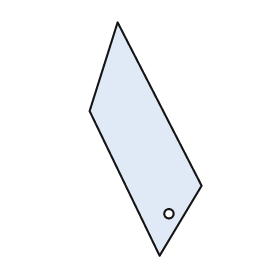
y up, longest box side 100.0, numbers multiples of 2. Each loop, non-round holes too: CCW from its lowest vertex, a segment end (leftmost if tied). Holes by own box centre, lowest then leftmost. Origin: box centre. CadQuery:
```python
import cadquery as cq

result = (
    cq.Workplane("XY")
    .moveTo(6.0, -50.0)
    .lineTo(24.0, -20.0)
    .lineTo(-12.0, 50.0)
    .lineTo(-24.0, 12.0)
    .close()
    .moveTo(10.0, -32.0)
    .circle(2.0)
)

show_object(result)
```